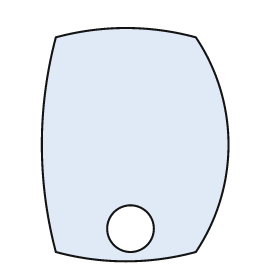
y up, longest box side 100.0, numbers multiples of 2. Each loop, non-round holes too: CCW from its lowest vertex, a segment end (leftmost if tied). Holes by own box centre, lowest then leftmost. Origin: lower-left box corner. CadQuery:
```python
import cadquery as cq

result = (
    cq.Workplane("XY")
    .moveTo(6.0, 4.0)
    .threePointArc((36.0, 0.0), (66.0, 4.0))
    .threePointArc((80.0, 50.0), (66.0, 96.0))
    .threePointArc((36.0, 100.0), (6.0, 96.0))
    .threePointArc((0.0, 50.0), (6.0, 4.0))
    .close()
    .moveTo(38.0, 14.0)
    .circle(10.0)
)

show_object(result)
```